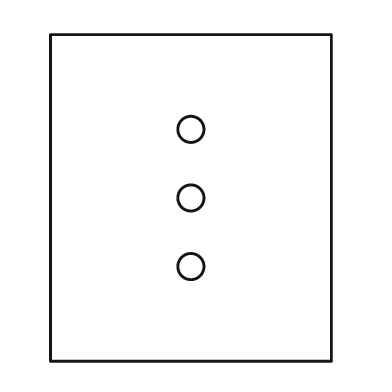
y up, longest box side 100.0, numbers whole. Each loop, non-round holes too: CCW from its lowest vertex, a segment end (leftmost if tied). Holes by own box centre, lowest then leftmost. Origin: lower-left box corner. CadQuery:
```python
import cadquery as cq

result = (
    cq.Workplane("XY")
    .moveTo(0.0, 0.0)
    .lineTo(86.0, 0.0)
    .lineTo(86.0, 100.0)
    .lineTo(0.0, 100.0)
    .close()
    .moveTo(43.0, 29.0)
    .circle(4.0)
    .moveTo(43.0, 50.0)
    .circle(4.0)
    .moveTo(43.0, 71.0)
    .circle(4.0)
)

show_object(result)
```